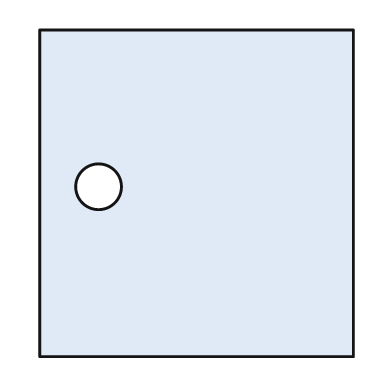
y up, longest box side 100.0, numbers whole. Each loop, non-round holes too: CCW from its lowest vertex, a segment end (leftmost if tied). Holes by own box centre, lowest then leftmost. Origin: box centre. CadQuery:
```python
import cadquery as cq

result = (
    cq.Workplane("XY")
    .moveTo(-48.0, -50.0)
    .lineTo(48.0, -50.0)
    .lineTo(48.0, 50.0)
    .lineTo(-48.0, 50.0)
    .close()
    .moveTo(-30.0, 2.0)
    .circle(7.0)
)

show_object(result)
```